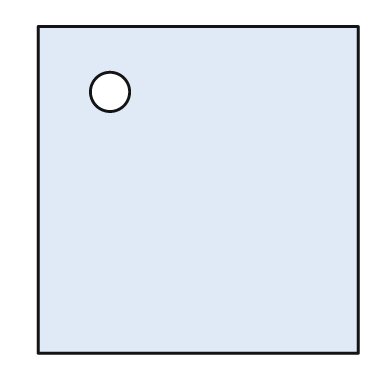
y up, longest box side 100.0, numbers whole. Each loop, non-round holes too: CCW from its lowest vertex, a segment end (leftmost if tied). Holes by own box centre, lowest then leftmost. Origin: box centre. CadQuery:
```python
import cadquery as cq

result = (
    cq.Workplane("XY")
    .moveTo(-49.0, -50.0)
    .lineTo(49.0, -50.0)
    .lineTo(49.0, 50.0)
    .lineTo(-49.0, 50.0)
    .close()
    .moveTo(-27.0, 30.0)
    .circle(6.0)
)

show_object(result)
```